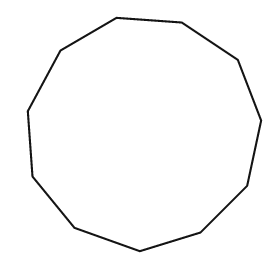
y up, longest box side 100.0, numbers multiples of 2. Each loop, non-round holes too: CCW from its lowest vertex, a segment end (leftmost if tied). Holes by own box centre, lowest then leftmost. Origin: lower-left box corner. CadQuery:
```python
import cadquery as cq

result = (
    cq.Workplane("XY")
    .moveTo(48.0, 0.0)
    .lineTo(74.0, 8.0)
    .lineTo(94.0, 28.0)
    .lineTo(100.0, 56.0)
    .lineTo(90.0, 82.0)
    .lineTo(66.0, 98.0)
    .lineTo(38.0, 100.0)
    .lineTo(14.0, 86.0)
    .lineTo(0.0, 60.0)
    .lineTo(2.0, 32.0)
    .lineTo(20.0, 10.0)
    .close()
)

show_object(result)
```